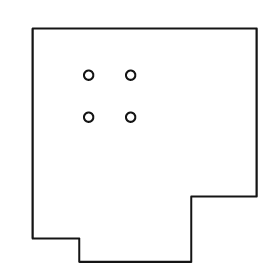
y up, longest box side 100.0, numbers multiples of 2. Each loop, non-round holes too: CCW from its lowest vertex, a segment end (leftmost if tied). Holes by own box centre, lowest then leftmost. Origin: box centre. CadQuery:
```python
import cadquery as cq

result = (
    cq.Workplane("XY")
    .moveTo(-28.0, -50.0)
    .lineTo(20.0, -50.0)
    .lineTo(20.0, -22.0)
    .lineTo(48.0, -22.0)
    .lineTo(48.0, 50.0)
    .lineTo(-48.0, 50.0)
    .lineTo(-48.0, -40.0)
    .lineTo(-28.0, -40.0)
    .close()
    .moveTo(-24.0, 12.0)
    .circle(2.0)
    .moveTo(-6.0, 12.0)
    .circle(2.0)
    .moveTo(-24.0, 30.0)
    .circle(2.0)
    .moveTo(-6.0, 30.0)
    .circle(2.0)
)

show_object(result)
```